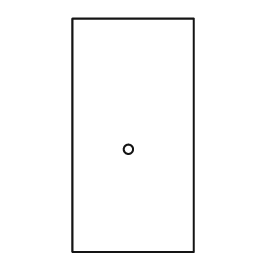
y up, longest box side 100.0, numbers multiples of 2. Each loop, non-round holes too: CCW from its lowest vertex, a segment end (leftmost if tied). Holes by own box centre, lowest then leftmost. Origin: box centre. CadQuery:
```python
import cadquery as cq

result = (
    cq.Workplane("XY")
    .moveTo(-26.0, -50.0)
    .lineTo(26.0, -50.0)
    .lineTo(26.0, 50.0)
    .lineTo(-26.0, 50.0)
    .close()
    .moveTo(-2.0, -6.0)
    .circle(2.0)
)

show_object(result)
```